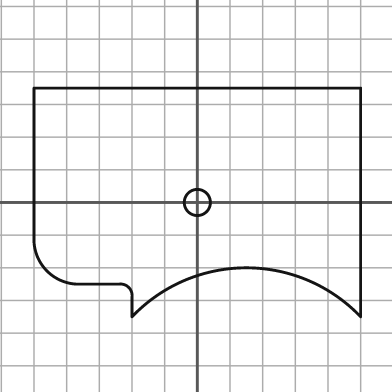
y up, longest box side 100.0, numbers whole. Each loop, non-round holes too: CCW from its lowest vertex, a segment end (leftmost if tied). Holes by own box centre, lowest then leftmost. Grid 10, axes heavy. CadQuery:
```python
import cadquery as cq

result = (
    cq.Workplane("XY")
    .moveTo(-20.0, -35.0)
    .threePointArc((15.0, -20.0), (50.0, -35.0))
    .lineTo(50.0, 35.0)
    .lineTo(-50.0, 35.0)
    .lineTo(-50.0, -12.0)
    .threePointArc((-46.0, -21.0), (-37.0, -25.0))
    .lineTo(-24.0, -25.0)
    .threePointArc((-21.0, -26.0), (-20.0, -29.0))
    .close()
    .moveTo(0.0, 0.0)
    .circle(4.0)
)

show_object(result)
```